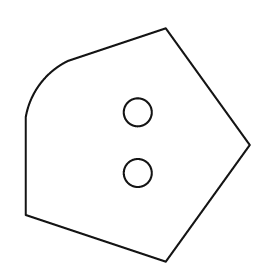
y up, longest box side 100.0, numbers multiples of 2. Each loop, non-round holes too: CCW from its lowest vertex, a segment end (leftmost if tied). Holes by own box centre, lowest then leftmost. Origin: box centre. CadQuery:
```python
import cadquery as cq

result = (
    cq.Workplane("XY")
    .moveTo(12.0, -50.0)
    .lineTo(48.0, 0.0)
    .lineTo(12.0, 50.0)
    .lineTo(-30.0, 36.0)
    .threePointArc((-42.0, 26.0), (-48.0, 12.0))
    .lineTo(-48.0, -30.0)
    .close()
    .moveTo(0.0, -12.0)
    .circle(6.0)
    .moveTo(0.0, 14.0)
    .circle(6.0)
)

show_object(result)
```